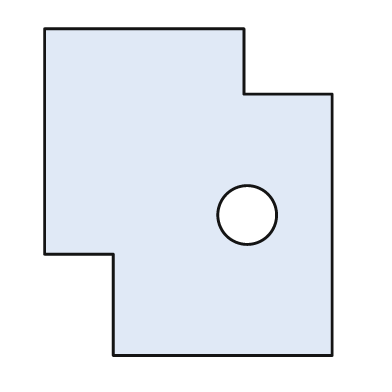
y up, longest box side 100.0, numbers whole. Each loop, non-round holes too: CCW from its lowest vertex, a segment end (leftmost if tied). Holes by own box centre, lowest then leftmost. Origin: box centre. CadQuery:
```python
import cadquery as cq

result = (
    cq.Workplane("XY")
    .moveTo(-23.0, -50.0)
    .lineTo(44.0, -50.0)
    .lineTo(44.0, 30.0)
    .lineTo(17.0, 30.0)
    .lineTo(17.0, 50.0)
    .lineTo(-44.0, 50.0)
    .lineTo(-44.0, -19.0)
    .lineTo(-23.0, -19.0)
    .close()
    .moveTo(18.0, -7.0)
    .circle(9.0)
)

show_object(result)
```